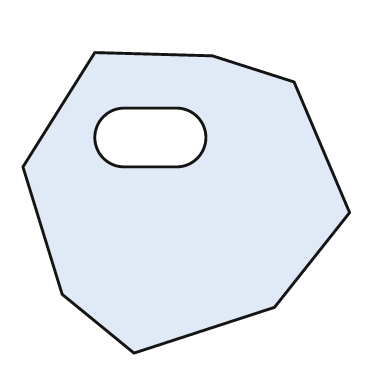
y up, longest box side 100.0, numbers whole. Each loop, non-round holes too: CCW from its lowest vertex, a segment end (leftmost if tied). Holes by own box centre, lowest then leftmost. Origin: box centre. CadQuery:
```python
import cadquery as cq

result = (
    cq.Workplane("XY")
    .moveTo(-16.0, -46.0)
    .lineTo(27.0, -32.0)
    .lineTo(50.0, -3.0)
    .lineTo(33.0, 37.0)
    .lineTo(8.0, 45.0)
    .lineTo(-28.0, 46.0)
    .lineTo(-50.0, 11.0)
    .lineTo(-38.0, -28.0)
    .close()
    .moveTo(-19.0, 11.0)
    .lineTo(-3.0, 11.0)
    .threePointArc((6.0, 20.0), (-3.0, 29.0))
    .lineTo(-19.0, 29.0)
    .threePointArc((-28.0, 20.0), (-19.0, 11.0))
    .close()
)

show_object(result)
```